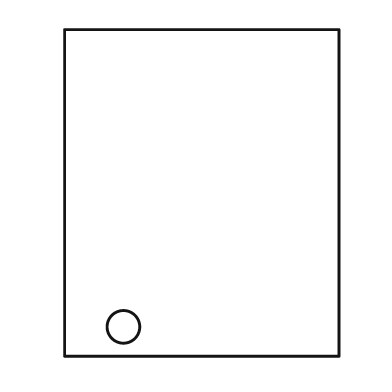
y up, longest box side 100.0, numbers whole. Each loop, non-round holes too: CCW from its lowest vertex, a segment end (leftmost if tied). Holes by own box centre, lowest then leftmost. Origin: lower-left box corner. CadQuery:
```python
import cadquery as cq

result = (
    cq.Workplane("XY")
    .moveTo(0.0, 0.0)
    .lineTo(84.0, 0.0)
    .lineTo(84.0, 100.0)
    .lineTo(0.0, 100.0)
    .close()
    .moveTo(18.0, 9.0)
    .circle(5.0)
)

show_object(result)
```